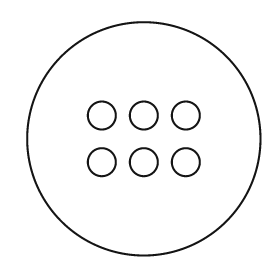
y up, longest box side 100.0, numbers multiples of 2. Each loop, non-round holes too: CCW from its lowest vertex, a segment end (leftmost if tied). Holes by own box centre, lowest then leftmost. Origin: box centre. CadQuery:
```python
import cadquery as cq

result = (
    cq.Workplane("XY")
    .moveTo(0.0, 0.0)
    .circle(50.0)
    .moveTo(-18.0, -10.0)
    .circle(6.0)
    .moveTo(0.0, -10.0)
    .circle(6.0)
    .moveTo(18.0, -10.0)
    .circle(6.0)
    .moveTo(-18.0, 10.0)
    .circle(6.0)
    .moveTo(0.0, 10.0)
    .circle(6.0)
    .moveTo(18.0, 10.0)
    .circle(6.0)
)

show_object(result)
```